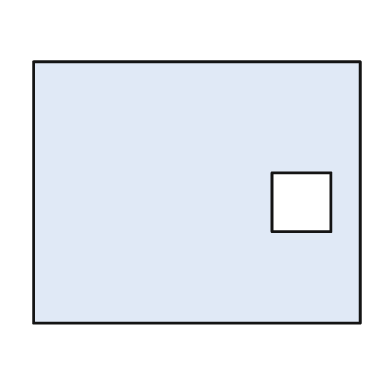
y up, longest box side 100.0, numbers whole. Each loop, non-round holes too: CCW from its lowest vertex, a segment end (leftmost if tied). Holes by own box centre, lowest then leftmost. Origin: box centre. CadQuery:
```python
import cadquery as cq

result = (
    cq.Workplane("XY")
    .moveTo(-50.0, -40.0)
    .lineTo(50.0, -40.0)
    .lineTo(50.0, 40.0)
    .lineTo(-50.0, 40.0)
    .close()
    .moveTo(23.0, -12.0)
    .lineTo(41.0, -12.0)
    .lineTo(41.0, 6.0)
    .lineTo(23.0, 6.0)
    .close()
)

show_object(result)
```